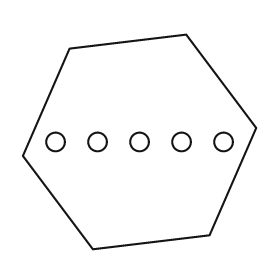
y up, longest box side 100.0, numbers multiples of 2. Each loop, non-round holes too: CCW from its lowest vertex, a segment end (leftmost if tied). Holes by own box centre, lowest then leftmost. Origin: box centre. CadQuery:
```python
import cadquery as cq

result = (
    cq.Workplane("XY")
    .moveTo(-20.0, -46.0)
    .lineTo(30.0, -40.0)
    .lineTo(50.0, 6.0)
    .lineTo(20.0, 46.0)
    .lineTo(-30.0, 40.0)
    .lineTo(-50.0, -6.0)
    .close()
    .moveTo(-36.0, 0.0)
    .circle(4.0)
    .moveTo(-18.0, 0.0)
    .circle(4.0)
    .moveTo(0.0, 0.0)
    .circle(4.0)
    .moveTo(18.0, 0.0)
    .circle(4.0)
    .moveTo(36.0, 0.0)
    .circle(4.0)
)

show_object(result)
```